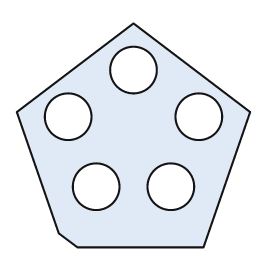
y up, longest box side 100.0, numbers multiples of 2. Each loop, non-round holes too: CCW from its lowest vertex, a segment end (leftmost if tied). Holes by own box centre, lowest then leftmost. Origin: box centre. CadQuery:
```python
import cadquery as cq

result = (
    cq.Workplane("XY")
    .moveTo(-24.0, -48.0)
    .lineTo(30.0, -48.0)
    .lineTo(50.0, 10.0)
    .lineTo(0.0, 48.0)
    .lineTo(-50.0, 10.0)
    .lineTo(-32.0, -42.0)
    .close()
    .moveTo(-16.0, -22.0)
    .circle(10.0)
    .moveTo(16.0, -22.0)
    .circle(10.0)
    .moveTo(-28.0, 8.0)
    .circle(10.0)
    .moveTo(28.0, 8.0)
    .circle(10.0)
    .moveTo(0.0, 28.0)
    .circle(10.0)
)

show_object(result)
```